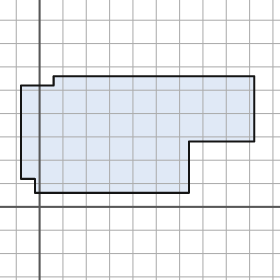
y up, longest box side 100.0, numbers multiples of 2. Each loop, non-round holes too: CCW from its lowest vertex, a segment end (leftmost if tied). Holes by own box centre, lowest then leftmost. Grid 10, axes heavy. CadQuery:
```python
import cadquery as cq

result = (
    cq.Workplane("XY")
    .moveTo(-2.0, 6.0)
    .lineTo(64.0, 6.0)
    .lineTo(64.0, 28.0)
    .lineTo(92.0, 28.0)
    .lineTo(92.0, 56.0)
    .lineTo(6.0, 56.0)
    .lineTo(6.0, 52.0)
    .lineTo(-8.0, 52.0)
    .lineTo(-8.0, 12.0)
    .lineTo(-2.0, 12.0)
    .close()
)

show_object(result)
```